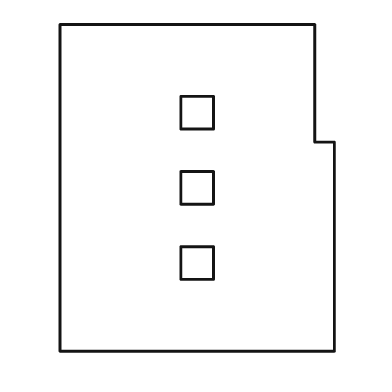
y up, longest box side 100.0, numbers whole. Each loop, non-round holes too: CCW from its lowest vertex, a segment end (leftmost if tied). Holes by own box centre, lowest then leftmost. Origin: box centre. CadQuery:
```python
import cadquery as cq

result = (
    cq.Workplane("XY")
    .moveTo(-42.0, -50.0)
    .lineTo(42.0, -50.0)
    .lineTo(42.0, 14.0)
    .lineTo(36.0, 14.0)
    .lineTo(36.0, 50.0)
    .lineTo(-42.0, 50.0)
    .close()
    .moveTo(-5.0, -28.0)
    .lineTo(5.0, -28.0)
    .lineTo(5.0, -18.0)
    .lineTo(-5.0, -18.0)
    .close()
    .moveTo(-5.0, -5.0)
    .lineTo(5.0, -5.0)
    .lineTo(5.0, 5.0)
    .lineTo(-5.0, 5.0)
    .close()
    .moveTo(-5.0, 18.0)
    .lineTo(5.0, 18.0)
    .lineTo(5.0, 28.0)
    .lineTo(-5.0, 28.0)
    .close()
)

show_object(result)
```